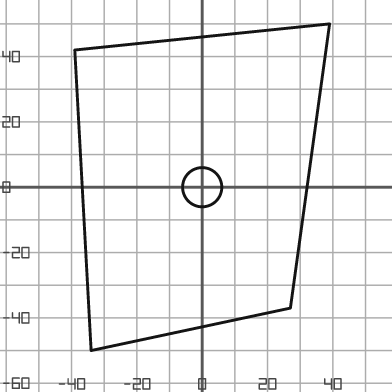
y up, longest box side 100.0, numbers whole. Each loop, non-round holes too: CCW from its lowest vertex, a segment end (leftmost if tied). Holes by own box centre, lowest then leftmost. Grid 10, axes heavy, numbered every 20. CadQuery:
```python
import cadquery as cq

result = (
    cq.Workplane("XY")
    .moveTo(-34.0, -50.0)
    .lineTo(27.0, -37.0)
    .lineTo(39.0, 50.0)
    .lineTo(-39.0, 42.0)
    .close()
    .moveTo(0.0, 0.0)
    .circle(6.0)
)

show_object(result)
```